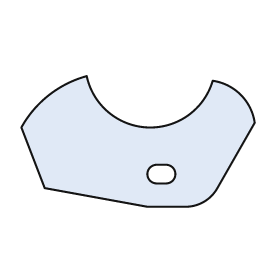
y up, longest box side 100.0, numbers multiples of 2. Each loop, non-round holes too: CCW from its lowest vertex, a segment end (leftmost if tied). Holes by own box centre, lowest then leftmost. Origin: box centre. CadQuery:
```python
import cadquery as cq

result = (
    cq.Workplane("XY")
    .moveTo(4.0, -28.0)
    .lineTo(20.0, -28.0)
    .threePointArc((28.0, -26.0), (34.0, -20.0))
    .lineTo(50.0, 8.0)
    .threePointArc((44.0, 20.0), (32.0, 26.0))
    .threePointArc((4.0, 6.0), (-22.0, 28.0))
    .threePointArc((-38.0, 20.0), (-50.0, 6.0))
    .lineTo(-40.0, -20.0)
    .close()
    .moveTo(8.0, -18.0)
    .lineTo(12.0, -18.0)
    .threePointArc((16.0, -14.0), (12.0, -10.0))
    .lineTo(8.0, -10.0)
    .threePointArc((4.0, -14.0), (8.0, -18.0))
    .close()
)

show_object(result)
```